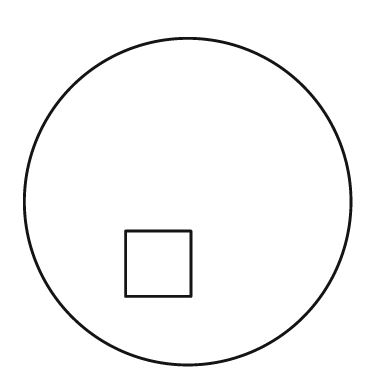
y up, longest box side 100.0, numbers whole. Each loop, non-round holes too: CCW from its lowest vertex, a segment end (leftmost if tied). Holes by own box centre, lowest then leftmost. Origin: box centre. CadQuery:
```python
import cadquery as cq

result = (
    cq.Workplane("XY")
    .moveTo(0.0, 0.0)
    .circle(50.0)
    .moveTo(-19.0, -29.0)
    .lineTo(1.0, -29.0)
    .lineTo(1.0, -9.0)
    .lineTo(-19.0, -9.0)
    .close()
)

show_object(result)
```